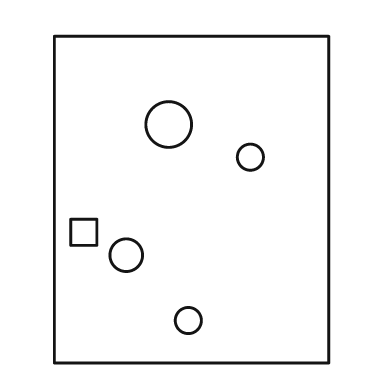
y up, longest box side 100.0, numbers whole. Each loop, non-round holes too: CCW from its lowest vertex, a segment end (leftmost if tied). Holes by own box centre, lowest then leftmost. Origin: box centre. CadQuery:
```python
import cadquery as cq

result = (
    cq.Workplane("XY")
    .moveTo(-42.0, -50.0)
    .lineTo(42.0, -50.0)
    .lineTo(42.0, 50.0)
    .lineTo(-42.0, 50.0)
    .close()
    .moveTo(-1.0, -37.0)
    .circle(4.0)
    .moveTo(-20.0, -17.0)
    .circle(5.0)
    .moveTo(-37.0, -14.0)
    .lineTo(-29.0, -14.0)
    .lineTo(-29.0, -6.0)
    .lineTo(-37.0, -6.0)
    .close()
    .moveTo(18.0, 13.0)
    .circle(4.0)
    .moveTo(-7.0, 23.0)
    .circle(7.0)
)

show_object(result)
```